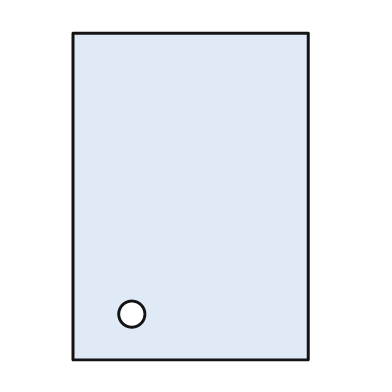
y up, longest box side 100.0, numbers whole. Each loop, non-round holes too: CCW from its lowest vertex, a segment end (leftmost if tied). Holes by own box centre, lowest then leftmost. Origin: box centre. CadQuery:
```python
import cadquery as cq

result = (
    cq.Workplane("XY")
    .moveTo(-36.0, -50.0)
    .lineTo(36.0, -50.0)
    .lineTo(36.0, 50.0)
    .lineTo(-36.0, 50.0)
    .close()
    .moveTo(-18.0, -36.0)
    .circle(4.0)
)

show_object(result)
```